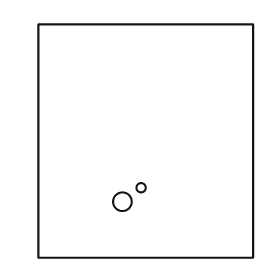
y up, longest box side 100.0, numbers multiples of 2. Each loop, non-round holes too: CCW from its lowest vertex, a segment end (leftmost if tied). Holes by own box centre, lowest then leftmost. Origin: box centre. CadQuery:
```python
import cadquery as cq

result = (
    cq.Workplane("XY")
    .moveTo(-46.0, -50.0)
    .lineTo(46.0, -50.0)
    .lineTo(46.0, 50.0)
    .lineTo(-46.0, 50.0)
    .close()
    .moveTo(-10.0, -26.0)
    .circle(4.0)
    .moveTo(-2.0, -20.0)
    .circle(2.0)
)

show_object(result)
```